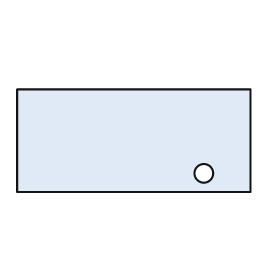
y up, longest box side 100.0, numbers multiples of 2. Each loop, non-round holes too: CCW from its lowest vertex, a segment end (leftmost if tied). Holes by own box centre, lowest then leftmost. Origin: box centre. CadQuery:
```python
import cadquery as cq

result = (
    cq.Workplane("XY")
    .moveTo(-50.0, -22.0)
    .lineTo(50.0, -22.0)
    .lineTo(50.0, 22.0)
    .lineTo(-50.0, 22.0)
    .close()
    .moveTo(30.0, -14.0)
    .circle(4.0)
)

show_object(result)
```